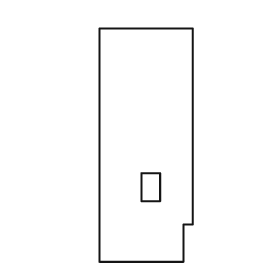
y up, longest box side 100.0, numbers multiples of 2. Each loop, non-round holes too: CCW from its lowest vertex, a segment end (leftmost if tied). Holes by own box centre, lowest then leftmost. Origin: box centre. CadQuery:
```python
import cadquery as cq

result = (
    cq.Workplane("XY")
    .moveTo(-20.0, -50.0)
    .lineTo(16.0, -50.0)
    .lineTo(16.0, -34.0)
    .lineTo(20.0, -34.0)
    .lineTo(20.0, 50.0)
    .lineTo(-20.0, 50.0)
    .close()
    .moveTo(-2.0, -24.0)
    .lineTo(6.0, -24.0)
    .lineTo(6.0, -12.0)
    .lineTo(-2.0, -12.0)
    .close()
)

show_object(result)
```